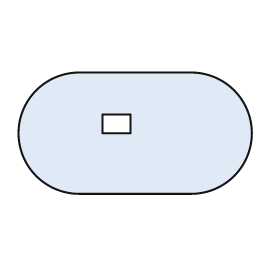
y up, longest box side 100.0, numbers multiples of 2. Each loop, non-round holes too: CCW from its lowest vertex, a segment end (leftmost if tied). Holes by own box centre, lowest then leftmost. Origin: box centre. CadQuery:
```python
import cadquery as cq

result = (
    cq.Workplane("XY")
    .moveTo(-24.0, -26.0)
    .lineTo(24.0, -26.0)
    .threePointArc((50.0, 0.0), (24.0, 26.0))
    .lineTo(-24.0, 26.0)
    .threePointArc((-50.0, 0.0), (-24.0, -26.0))
    .close()
    .moveTo(-14.0, 0.0)
    .lineTo(-2.0, 0.0)
    .lineTo(-2.0, 8.0)
    .lineTo(-14.0, 8.0)
    .close()
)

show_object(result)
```